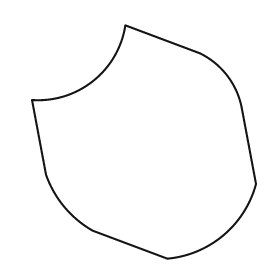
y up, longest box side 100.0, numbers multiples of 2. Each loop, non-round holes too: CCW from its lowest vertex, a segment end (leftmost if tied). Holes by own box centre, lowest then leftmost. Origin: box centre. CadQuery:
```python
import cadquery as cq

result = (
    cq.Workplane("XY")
    .moveTo(10.0, -50.0)
    .threePointArc((34.0, -40.0), (48.0, -18.0))
    .lineTo(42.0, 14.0)
    .threePointArc((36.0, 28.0), (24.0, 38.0))
    .lineTo(-8.0, 50.0)
    .threePointArc((-22.0, 26.0), (-48.0, 18.0))
    .lineTo(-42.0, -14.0)
    .threePointArc((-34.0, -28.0), (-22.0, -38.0))
    .close()
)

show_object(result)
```